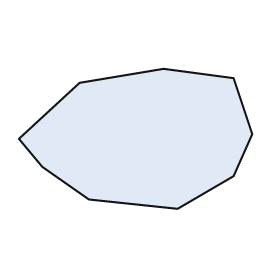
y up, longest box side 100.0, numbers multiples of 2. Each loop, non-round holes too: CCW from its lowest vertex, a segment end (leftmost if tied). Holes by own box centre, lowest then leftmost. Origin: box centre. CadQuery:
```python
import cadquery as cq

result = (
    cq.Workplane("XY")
    .moveTo(18.0, -30.0)
    .lineTo(42.0, -16.0)
    .lineTo(50.0, 2.0)
    .lineTo(42.0, 26.0)
    .lineTo(12.0, 30.0)
    .lineTo(-24.0, 24.0)
    .lineTo(-50.0, 0.0)
    .lineTo(-40.0, -12.0)
    .lineTo(-20.0, -26.0)
    .close()
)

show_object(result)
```